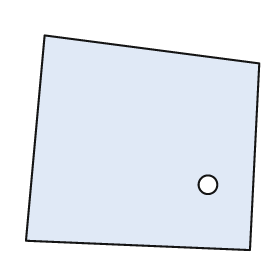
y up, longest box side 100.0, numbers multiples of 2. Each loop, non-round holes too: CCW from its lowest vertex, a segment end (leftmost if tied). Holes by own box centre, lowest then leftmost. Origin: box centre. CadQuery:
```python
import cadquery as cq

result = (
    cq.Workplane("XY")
    .moveTo(46.0, -46.0)
    .lineTo(50.0, 34.0)
    .lineTo(-42.0, 46.0)
    .lineTo(-50.0, -42.0)
    .close()
    .moveTo(28.0, -18.0)
    .circle(4.0)
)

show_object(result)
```